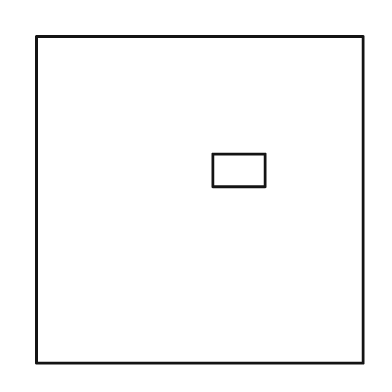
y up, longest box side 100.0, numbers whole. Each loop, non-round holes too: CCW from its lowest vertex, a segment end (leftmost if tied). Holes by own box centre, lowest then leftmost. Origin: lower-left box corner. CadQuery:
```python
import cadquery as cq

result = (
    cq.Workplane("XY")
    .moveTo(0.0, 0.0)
    .lineTo(100.0, 0.0)
    .lineTo(100.0, 100.0)
    .lineTo(0.0, 100.0)
    .close()
    .moveTo(54.0, 54.0)
    .lineTo(70.0, 54.0)
    .lineTo(70.0, 64.0)
    .lineTo(54.0, 64.0)
    .close()
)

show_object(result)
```